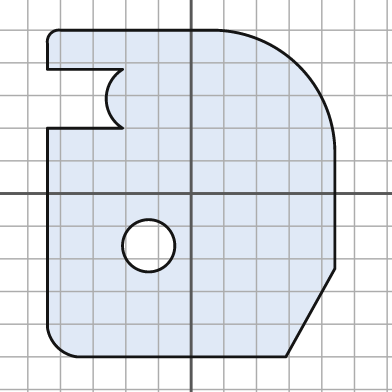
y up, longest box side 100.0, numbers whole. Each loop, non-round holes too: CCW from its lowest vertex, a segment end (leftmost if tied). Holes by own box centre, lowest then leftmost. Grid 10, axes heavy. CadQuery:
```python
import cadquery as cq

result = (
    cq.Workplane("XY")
    .moveTo(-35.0, -50.0)
    .lineTo(29.0, -50.0)
    .lineTo(44.0, -23.0)
    .lineTo(44.0, 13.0)
    .threePointArc((33.0, 39.0), (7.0, 50.0))
    .lineTo(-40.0, 50.0)
    .threePointArc((-43.0, 49.0), (-44.0, 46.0))
    .lineTo(-44.0, 38.0)
    .lineTo(-21.0, 38.0)
    .threePointArc((-26.0, 29.0), (-21.0, 20.0))
    .lineTo(-44.0, 20.0)
    .lineTo(-44.0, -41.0)
    .threePointArc((-41.0, -47.0), (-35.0, -50.0))
    .close()
    .moveTo(-13.0, -16.0)
    .circle(8.0)
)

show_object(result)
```